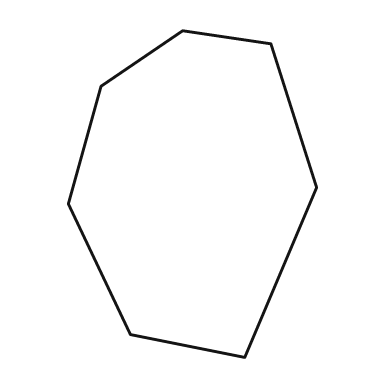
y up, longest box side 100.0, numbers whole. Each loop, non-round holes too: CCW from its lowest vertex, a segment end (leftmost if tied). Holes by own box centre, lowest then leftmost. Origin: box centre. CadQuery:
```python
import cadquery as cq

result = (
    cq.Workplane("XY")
    .moveTo(16.0, -50.0)
    .lineTo(38.0, 2.0)
    .lineTo(24.0, 46.0)
    .lineTo(-3.0, 50.0)
    .lineTo(-28.0, 33.0)
    .lineTo(-38.0, -3.0)
    .lineTo(-19.0, -43.0)
    .close()
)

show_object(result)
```